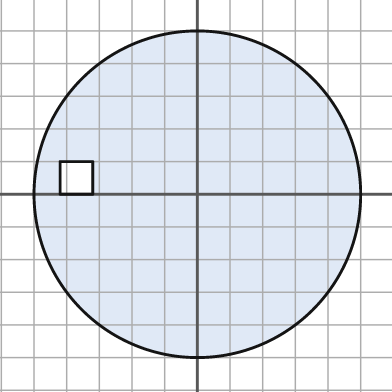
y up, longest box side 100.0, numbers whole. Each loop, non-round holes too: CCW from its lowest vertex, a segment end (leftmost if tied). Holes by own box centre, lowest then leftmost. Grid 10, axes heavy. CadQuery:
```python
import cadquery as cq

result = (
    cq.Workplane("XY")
    .moveTo(0.0, 0.0)
    .circle(50.0)
    .moveTo(-42.0, 0.0)
    .lineTo(-32.0, 0.0)
    .lineTo(-32.0, 10.0)
    .lineTo(-42.0, 10.0)
    .close()
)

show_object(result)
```